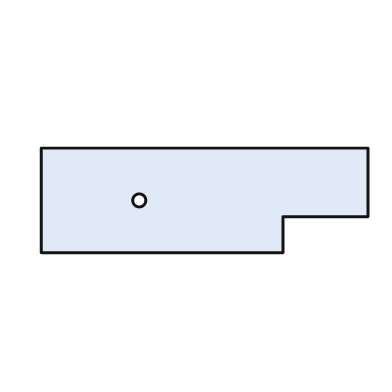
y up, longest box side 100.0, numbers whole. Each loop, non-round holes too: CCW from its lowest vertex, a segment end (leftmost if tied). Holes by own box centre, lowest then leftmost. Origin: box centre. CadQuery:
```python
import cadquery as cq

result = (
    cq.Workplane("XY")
    .moveTo(-50.0, -16.0)
    .lineTo(24.0, -16.0)
    .lineTo(24.0, -5.0)
    .lineTo(50.0, -5.0)
    .lineTo(50.0, 16.0)
    .lineTo(-50.0, 16.0)
    .close()
    .moveTo(-20.0, 0.0)
    .circle(2.0)
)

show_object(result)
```